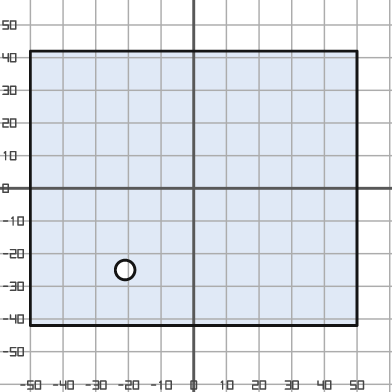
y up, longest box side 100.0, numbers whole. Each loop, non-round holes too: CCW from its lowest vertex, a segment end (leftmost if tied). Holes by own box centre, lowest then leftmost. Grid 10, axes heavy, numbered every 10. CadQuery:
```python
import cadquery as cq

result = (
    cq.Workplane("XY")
    .moveTo(-50.0, -42.0)
    .lineTo(50.0, -42.0)
    .lineTo(50.0, 42.0)
    .lineTo(-50.0, 42.0)
    .close()
    .moveTo(-21.0, -25.0)
    .circle(3.0)
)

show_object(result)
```